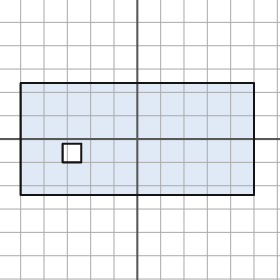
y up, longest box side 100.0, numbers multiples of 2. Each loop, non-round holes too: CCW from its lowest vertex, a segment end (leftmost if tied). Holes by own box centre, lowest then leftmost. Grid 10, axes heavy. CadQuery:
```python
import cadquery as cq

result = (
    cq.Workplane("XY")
    .moveTo(-50.0, -24.0)
    .lineTo(50.0, -24.0)
    .lineTo(50.0, 24.0)
    .lineTo(-50.0, 24.0)
    .close()
    .moveTo(-32.0, -10.0)
    .lineTo(-24.0, -10.0)
    .lineTo(-24.0, -2.0)
    .lineTo(-32.0, -2.0)
    .close()
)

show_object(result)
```